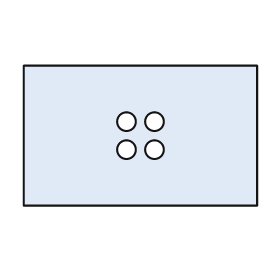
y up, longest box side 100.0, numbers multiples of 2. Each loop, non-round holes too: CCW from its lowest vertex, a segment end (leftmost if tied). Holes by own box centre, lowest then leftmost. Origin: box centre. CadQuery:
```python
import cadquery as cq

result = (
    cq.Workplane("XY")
    .moveTo(-50.0, -30.0)
    .lineTo(50.0, -30.0)
    .lineTo(50.0, 30.0)
    .lineTo(-50.0, 30.0)
    .close()
    .moveTo(-6.0, -6.0)
    .circle(4.0)
    .moveTo(6.0, -6.0)
    .circle(4.0)
    .moveTo(-6.0, 6.0)
    .circle(4.0)
    .moveTo(6.0, 6.0)
    .circle(4.0)
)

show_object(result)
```